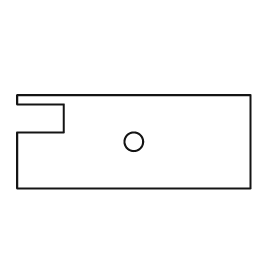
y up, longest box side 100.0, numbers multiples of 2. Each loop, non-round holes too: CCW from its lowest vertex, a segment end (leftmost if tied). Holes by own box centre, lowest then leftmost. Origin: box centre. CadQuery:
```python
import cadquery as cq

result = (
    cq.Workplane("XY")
    .moveTo(-50.0, -20.0)
    .lineTo(50.0, -20.0)
    .lineTo(50.0, 20.0)
    .lineTo(-50.0, 20.0)
    .lineTo(-50.0, 16.0)
    .lineTo(-30.0, 16.0)
    .lineTo(-30.0, 4.0)
    .lineTo(-50.0, 4.0)
    .close()
    .moveTo(0.0, 0.0)
    .circle(4.0)
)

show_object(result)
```